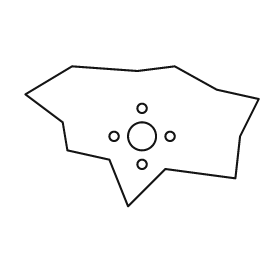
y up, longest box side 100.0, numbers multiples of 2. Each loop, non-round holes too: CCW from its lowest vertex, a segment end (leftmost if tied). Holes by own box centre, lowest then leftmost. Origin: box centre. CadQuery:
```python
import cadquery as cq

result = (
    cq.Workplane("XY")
    .moveTo(-6.0, -30.0)
    .lineTo(10.0, -14.0)
    .lineTo(40.0, -18.0)
    .lineTo(42.0, 0.0)
    .lineTo(50.0, 16.0)
    .lineTo(32.0, 20.0)
    .lineTo(14.0, 30.0)
    .lineTo(-2.0, 28.0)
    .lineTo(-30.0, 30.0)
    .lineTo(-50.0, 18.0)
    .lineTo(-34.0, 6.0)
    .lineTo(-32.0, -6.0)
    .lineTo(-14.0, -10.0)
    .close()
    .moveTo(0.0, -12.0)
    .circle(2.0)
    .moveTo(-12.0, 0.0)
    .circle(2.0)
    .moveTo(0.0, 0.0)
    .circle(6.0)
    .moveTo(12.0, 0.0)
    .circle(2.0)
    .moveTo(0.0, 12.0)
    .circle(2.0)
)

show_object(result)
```